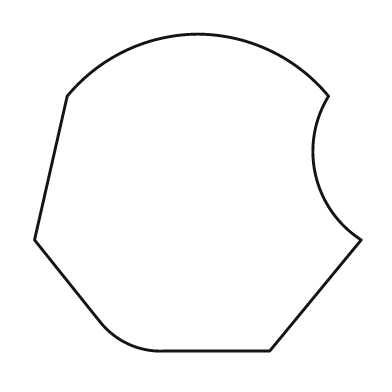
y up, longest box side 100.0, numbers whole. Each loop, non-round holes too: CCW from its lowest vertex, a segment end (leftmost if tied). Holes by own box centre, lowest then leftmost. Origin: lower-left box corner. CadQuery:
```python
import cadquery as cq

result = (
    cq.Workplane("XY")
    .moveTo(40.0, 0.0)
    .lineTo(72.0, 0.0)
    .lineTo(100.0, 34.0)
    .threePointArc((86.0, 54.0), (90.0, 78.0))
    .threePointArc((72.0, 92.0), (50.0, 97.0))
    .threePointArc((28.0, 92.0), (10.0, 78.0))
    .lineTo(0.0, 34.0)
    .lineTo(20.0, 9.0)
    .threePointArc((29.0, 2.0), (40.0, 0.0))
    .close()
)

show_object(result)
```